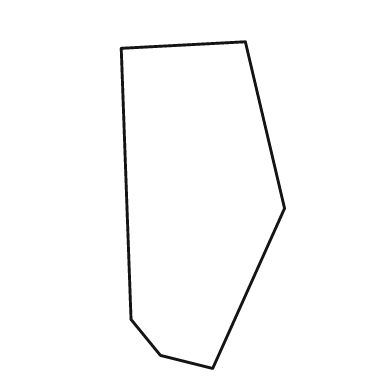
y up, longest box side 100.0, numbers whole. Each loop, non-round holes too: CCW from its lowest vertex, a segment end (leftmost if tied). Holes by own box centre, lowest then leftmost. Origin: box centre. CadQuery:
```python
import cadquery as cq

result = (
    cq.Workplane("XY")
    .moveTo(3.0, -50.0)
    .lineTo(25.0, -1.0)
    .lineTo(13.0, 50.0)
    .lineTo(-25.0, 48.0)
    .lineTo(-22.0, -35.0)
    .lineTo(-13.0, -46.0)
    .close()
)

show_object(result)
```